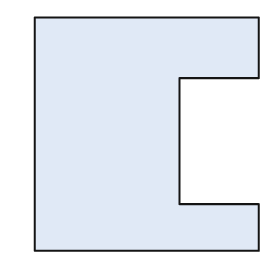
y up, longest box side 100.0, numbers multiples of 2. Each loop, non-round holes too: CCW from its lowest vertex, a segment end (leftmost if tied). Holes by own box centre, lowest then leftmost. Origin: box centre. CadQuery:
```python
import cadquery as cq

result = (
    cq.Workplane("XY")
    .moveTo(-48.0, -50.0)
    .lineTo(48.0, -50.0)
    .lineTo(48.0, -30.0)
    .lineTo(14.0, -30.0)
    .lineTo(14.0, 24.0)
    .lineTo(48.0, 24.0)
    .lineTo(48.0, 50.0)
    .lineTo(-48.0, 50.0)
    .close()
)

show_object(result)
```